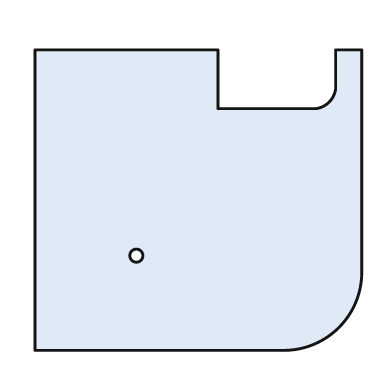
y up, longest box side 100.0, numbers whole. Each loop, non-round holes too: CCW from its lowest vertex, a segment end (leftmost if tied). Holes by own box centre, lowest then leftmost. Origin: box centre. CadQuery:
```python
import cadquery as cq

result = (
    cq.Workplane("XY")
    .moveTo(-50.0, -46.0)
    .lineTo(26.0, -46.0)
    .threePointArc((43.0, -39.0), (50.0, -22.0))
    .lineTo(50.0, 46.0)
    .lineTo(42.0, 46.0)
    .lineTo(42.0, 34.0)
    .threePointArc((40.0, 30.0), (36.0, 28.0))
    .lineTo(6.0, 28.0)
    .lineTo(6.0, 46.0)
    .lineTo(-50.0, 46.0)
    .close()
    .moveTo(-19.0, -17.0)
    .circle(2.0)
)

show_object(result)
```